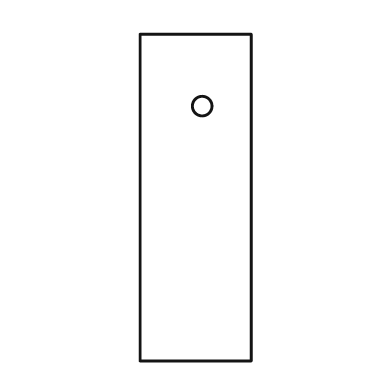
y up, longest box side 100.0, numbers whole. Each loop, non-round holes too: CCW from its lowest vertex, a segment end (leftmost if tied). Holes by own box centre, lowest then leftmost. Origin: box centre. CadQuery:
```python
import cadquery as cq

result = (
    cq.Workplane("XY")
    .moveTo(-17.0, -50.0)
    .lineTo(17.0, -50.0)
    .lineTo(17.0, 50.0)
    .lineTo(-17.0, 50.0)
    .close()
    .moveTo(2.0, 28.0)
    .circle(3.0)
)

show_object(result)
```